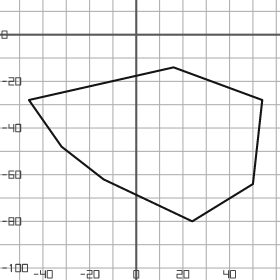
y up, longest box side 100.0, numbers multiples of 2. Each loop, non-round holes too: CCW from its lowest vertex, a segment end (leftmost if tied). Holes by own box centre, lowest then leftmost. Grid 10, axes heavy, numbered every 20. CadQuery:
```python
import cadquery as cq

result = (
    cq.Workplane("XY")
    .moveTo(24.0, -80.0)
    .lineTo(50.0, -64.0)
    .lineTo(54.0, -28.0)
    .lineTo(16.0, -14.0)
    .lineTo(-46.0, -28.0)
    .lineTo(-32.0, -48.0)
    .lineTo(-14.0, -62.0)
    .close()
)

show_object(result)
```